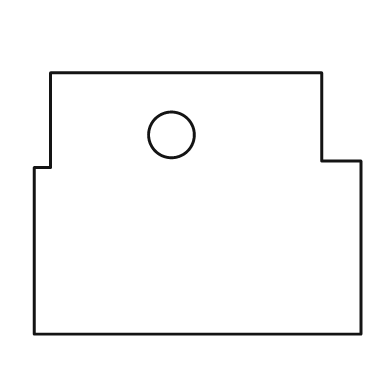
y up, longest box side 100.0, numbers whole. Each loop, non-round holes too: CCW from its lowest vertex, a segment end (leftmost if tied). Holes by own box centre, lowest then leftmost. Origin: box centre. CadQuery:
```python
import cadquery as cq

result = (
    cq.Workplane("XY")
    .moveTo(-50.0, -40.0)
    .lineTo(50.0, -40.0)
    .lineTo(50.0, 13.0)
    .lineTo(38.0, 13.0)
    .lineTo(38.0, 40.0)
    .lineTo(-45.0, 40.0)
    .lineTo(-45.0, 11.0)
    .lineTo(-50.0, 11.0)
    .close()
    .moveTo(-8.0, 21.0)
    .circle(7.0)
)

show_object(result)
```